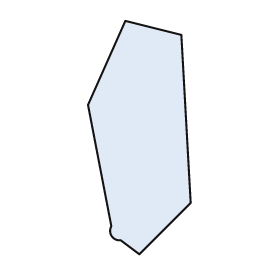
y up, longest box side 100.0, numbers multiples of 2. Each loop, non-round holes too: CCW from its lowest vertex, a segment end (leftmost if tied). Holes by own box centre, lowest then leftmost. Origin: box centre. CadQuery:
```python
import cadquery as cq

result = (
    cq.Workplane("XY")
    .moveTo(0.0, -50.0)
    .lineTo(22.0, -28.0)
    .lineTo(18.0, 44.0)
    .lineTo(-6.0, 50.0)
    .lineTo(-22.0, 14.0)
    .lineTo(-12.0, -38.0)
    .threePointArc((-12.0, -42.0), (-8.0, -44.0))
    .close()
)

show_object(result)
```